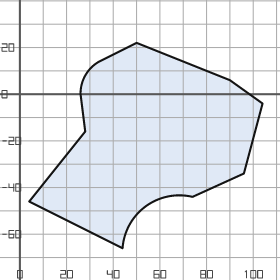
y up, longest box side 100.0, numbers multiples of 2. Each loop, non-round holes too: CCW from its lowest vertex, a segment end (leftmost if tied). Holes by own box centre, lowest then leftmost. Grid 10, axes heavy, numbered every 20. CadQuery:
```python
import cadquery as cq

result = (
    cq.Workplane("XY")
    .moveTo(44.0, -66.0)
    .threePointArc((54.0, -48.0), (74.0, -44.0))
    .lineTo(96.0, -34.0)
    .lineTo(104.0, -4.0)
    .lineTo(90.0, 6.0)
    .lineTo(50.0, 22.0)
    .lineTo(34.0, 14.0)
    .threePointArc((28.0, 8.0), (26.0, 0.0))
    .lineTo(28.0, -16.0)
    .lineTo(4.0, -46.0)
    .close()
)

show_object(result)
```